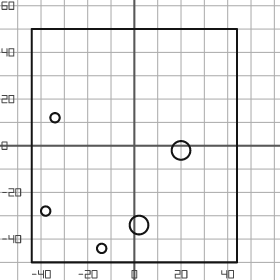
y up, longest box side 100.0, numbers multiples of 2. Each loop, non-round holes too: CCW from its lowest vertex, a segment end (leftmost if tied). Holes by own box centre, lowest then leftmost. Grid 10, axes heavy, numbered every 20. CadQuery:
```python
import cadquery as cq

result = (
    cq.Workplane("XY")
    .moveTo(-44.0, -50.0)
    .lineTo(44.0, -50.0)
    .lineTo(44.0, 50.0)
    .lineTo(-44.0, 50.0)
    .close()
    .moveTo(-14.0, -44.0)
    .circle(2.0)
    .moveTo(2.0, -34.0)
    .circle(4.0)
    .moveTo(-38.0, -28.0)
    .circle(2.0)
    .moveTo(20.0, -2.0)
    .circle(4.0)
    .moveTo(-34.0, 12.0)
    .circle(2.0)
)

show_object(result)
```